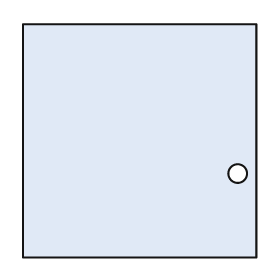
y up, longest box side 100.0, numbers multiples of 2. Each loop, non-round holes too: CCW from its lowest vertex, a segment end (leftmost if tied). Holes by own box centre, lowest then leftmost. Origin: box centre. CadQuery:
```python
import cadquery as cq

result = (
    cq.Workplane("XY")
    .moveTo(-50.0, -50.0)
    .lineTo(50.0, -50.0)
    .lineTo(50.0, 50.0)
    .lineTo(-50.0, 50.0)
    .close()
    .moveTo(42.0, -14.0)
    .circle(4.0)
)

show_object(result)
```